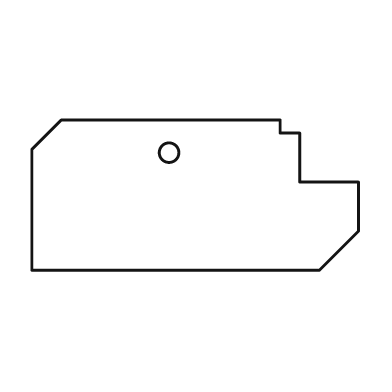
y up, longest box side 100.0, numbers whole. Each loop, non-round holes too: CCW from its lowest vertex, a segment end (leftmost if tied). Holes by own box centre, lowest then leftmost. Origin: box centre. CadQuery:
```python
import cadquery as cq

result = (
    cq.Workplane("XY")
    .moveTo(-50.0, -23.0)
    .lineTo(38.0, -23.0)
    .lineTo(50.0, -11.0)
    .lineTo(50.0, 4.0)
    .lineTo(32.0, 4.0)
    .lineTo(32.0, 19.0)
    .lineTo(26.0, 19.0)
    .lineTo(26.0, 23.0)
    .lineTo(-41.0, 23.0)
    .lineTo(-50.0, 14.0)
    .close()
    .moveTo(-8.0, 13.0)
    .circle(3.0)
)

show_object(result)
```